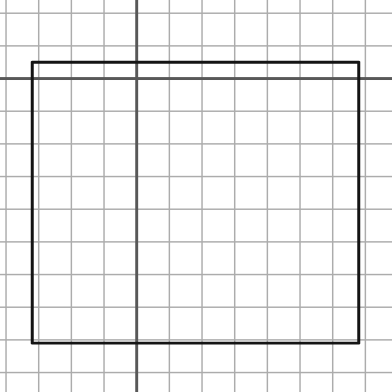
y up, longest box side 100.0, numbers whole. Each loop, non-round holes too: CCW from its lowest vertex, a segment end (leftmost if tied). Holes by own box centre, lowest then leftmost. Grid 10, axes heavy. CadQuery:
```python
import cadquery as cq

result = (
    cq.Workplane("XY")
    .moveTo(-32.0, -81.0)
    .lineTo(68.0, -81.0)
    .lineTo(68.0, 5.0)
    .lineTo(-32.0, 5.0)
    .close()
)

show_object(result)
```